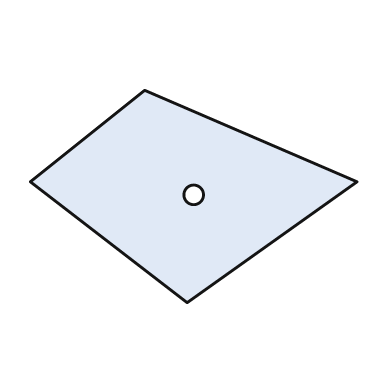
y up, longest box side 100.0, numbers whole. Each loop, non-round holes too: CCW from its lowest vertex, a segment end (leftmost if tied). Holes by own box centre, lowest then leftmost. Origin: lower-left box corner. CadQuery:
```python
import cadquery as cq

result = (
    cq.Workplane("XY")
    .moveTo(48.0, 0.0)
    .lineTo(100.0, 37.0)
    .lineTo(35.0, 65.0)
    .lineTo(0.0, 37.0)
    .close()
    .moveTo(50.0, 33.0)
    .circle(3.0)
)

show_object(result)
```